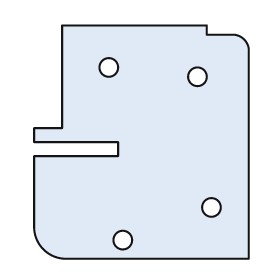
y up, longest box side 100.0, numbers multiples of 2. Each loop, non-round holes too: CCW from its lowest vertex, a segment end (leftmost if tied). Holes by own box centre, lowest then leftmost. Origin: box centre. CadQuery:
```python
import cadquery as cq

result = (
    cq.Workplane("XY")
    .moveTo(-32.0, -50.0)
    .lineTo(46.0, -50.0)
    .lineTo(46.0, 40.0)
    .threePointArc((44.0, 44.0), (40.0, 46.0))
    .lineTo(28.0, 46.0)
    .lineTo(28.0, 50.0)
    .lineTo(-34.0, 50.0)
    .lineTo(-34.0, 6.0)
    .lineTo(-46.0, 6.0)
    .lineTo(-46.0, 0.0)
    .lineTo(-10.0, 0.0)
    .lineTo(-10.0, -6.0)
    .lineTo(-46.0, -6.0)
    .lineTo(-46.0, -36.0)
    .threePointArc((-42.0, -46.0), (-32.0, -50.0))
    .close()
    .moveTo(-8.0, -42.0)
    .circle(4.0)
    .moveTo(30.0, -28.0)
    .circle(4.0)
    .moveTo(24.0, 28.0)
    .circle(4.0)
    .moveTo(-14.0, 32.0)
    .circle(4.0)
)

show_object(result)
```